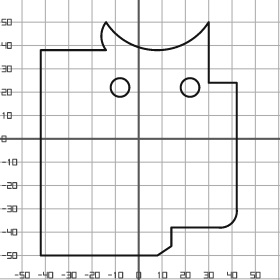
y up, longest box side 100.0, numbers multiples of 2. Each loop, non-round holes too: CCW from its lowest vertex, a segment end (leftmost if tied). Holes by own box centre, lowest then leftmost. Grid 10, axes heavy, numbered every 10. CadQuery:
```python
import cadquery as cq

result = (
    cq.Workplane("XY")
    .moveTo(-42.0, -50.0)
    .lineTo(8.0, -50.0)
    .lineTo(14.0, -46.0)
    .lineTo(14.0, -38.0)
    .lineTo(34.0, -38.0)
    .threePointArc((40.0, -36.0), (42.0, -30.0))
    .lineTo(42.0, 24.0)
    .lineTo(30.0, 24.0)
    .lineTo(30.0, 50.0)
    .threePointArc((8.0, 38.0), (-14.0, 50.0))
    .threePointArc((-16.0, 44.0), (-14.0, 38.0))
    .lineTo(-42.0, 38.0)
    .close()
    .moveTo(-8.0, 22.0)
    .circle(4.0)
    .moveTo(22.0, 22.0)
    .circle(4.0)
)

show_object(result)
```